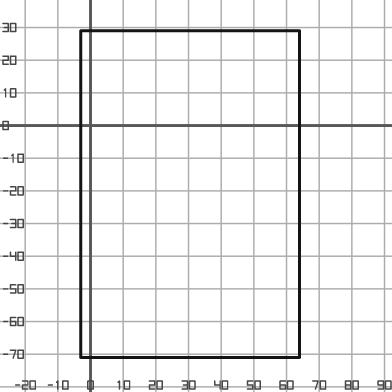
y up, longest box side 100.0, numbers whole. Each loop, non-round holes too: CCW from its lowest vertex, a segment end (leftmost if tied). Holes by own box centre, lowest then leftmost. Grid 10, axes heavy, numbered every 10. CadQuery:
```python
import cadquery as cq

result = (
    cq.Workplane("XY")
    .moveTo(-3.0, -71.0)
    .lineTo(64.0, -71.0)
    .lineTo(64.0, 29.0)
    .lineTo(-3.0, 29.0)
    .close()
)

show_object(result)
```